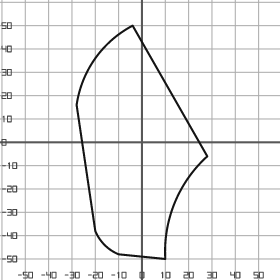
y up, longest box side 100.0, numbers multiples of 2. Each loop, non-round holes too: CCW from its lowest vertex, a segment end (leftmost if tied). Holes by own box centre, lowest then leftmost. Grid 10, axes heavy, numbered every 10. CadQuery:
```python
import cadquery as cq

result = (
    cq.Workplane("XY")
    .moveTo(10.0, -50.0)
    .threePointArc((14.0, -26.0), (28.0, -6.0))
    .lineTo(-4.0, 50.0)
    .threePointArc((-20.0, 36.0), (-28.0, 16.0))
    .lineTo(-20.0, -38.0)
    .threePointArc((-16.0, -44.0), (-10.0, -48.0))
    .close()
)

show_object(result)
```